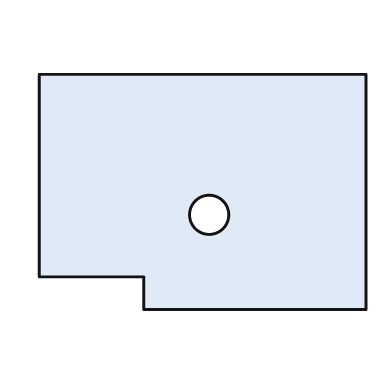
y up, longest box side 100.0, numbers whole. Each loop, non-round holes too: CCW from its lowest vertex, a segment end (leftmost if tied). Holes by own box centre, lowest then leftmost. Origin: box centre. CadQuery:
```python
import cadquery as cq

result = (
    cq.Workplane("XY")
    .moveTo(-18.0, -36.0)
    .lineTo(50.0, -36.0)
    .lineTo(50.0, 36.0)
    .lineTo(-50.0, 36.0)
    .lineTo(-50.0, -26.0)
    .lineTo(-18.0, -26.0)
    .close()
    .moveTo(2.0, -7.0)
    .circle(6.0)
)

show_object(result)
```